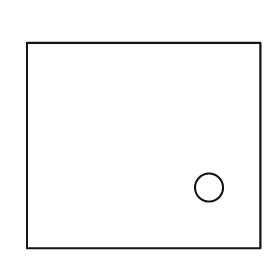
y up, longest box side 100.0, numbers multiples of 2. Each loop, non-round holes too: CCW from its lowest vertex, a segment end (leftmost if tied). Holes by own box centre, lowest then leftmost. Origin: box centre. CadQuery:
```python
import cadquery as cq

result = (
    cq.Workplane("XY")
    .moveTo(-50.0, -44.0)
    .lineTo(50.0, -44.0)
    .lineTo(50.0, 44.0)
    .lineTo(-50.0, 44.0)
    .close()
    .moveTo(28.0, -18.0)
    .circle(6.0)
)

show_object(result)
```